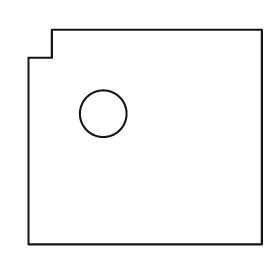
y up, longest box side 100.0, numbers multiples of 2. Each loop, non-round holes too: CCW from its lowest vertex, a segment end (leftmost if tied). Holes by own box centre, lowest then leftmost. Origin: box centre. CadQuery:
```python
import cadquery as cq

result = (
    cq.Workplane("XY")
    .moveTo(-50.0, -46.0)
    .lineTo(50.0, -46.0)
    .lineTo(50.0, 46.0)
    .lineTo(-40.0, 46.0)
    .lineTo(-40.0, 34.0)
    .lineTo(-50.0, 34.0)
    .close()
    .moveTo(-18.0, 10.0)
    .circle(10.0)
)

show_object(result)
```